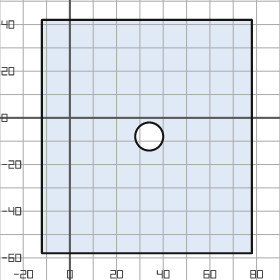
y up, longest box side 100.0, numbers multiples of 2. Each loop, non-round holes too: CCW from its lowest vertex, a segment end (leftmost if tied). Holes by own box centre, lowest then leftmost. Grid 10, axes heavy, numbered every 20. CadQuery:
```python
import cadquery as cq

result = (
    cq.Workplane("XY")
    .moveTo(-12.0, -58.0)
    .lineTo(78.0, -58.0)
    .lineTo(78.0, 42.0)
    .lineTo(-12.0, 42.0)
    .close()
    .moveTo(34.0, -8.0)
    .circle(6.0)
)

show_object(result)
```